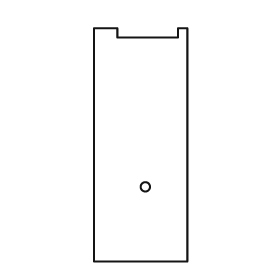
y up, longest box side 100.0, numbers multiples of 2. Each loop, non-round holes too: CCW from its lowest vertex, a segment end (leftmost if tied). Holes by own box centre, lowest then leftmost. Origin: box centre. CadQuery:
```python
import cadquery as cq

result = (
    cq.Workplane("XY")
    .moveTo(-20.0, -50.0)
    .lineTo(20.0, -50.0)
    .lineTo(20.0, 50.0)
    .lineTo(16.0, 50.0)
    .lineTo(16.0, 46.0)
    .lineTo(-10.0, 46.0)
    .lineTo(-10.0, 50.0)
    .lineTo(-20.0, 50.0)
    .close()
    .moveTo(2.0, -18.0)
    .circle(2.0)
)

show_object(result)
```